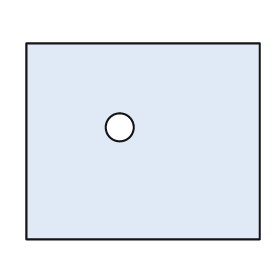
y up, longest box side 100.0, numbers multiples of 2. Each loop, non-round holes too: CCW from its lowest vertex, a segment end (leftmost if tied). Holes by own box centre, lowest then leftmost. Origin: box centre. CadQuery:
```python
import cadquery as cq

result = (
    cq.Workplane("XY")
    .moveTo(-50.0, -42.0)
    .lineTo(50.0, -42.0)
    .lineTo(50.0, 42.0)
    .lineTo(-50.0, 42.0)
    .close()
    .moveTo(-10.0, 6.0)
    .circle(6.0)
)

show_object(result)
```